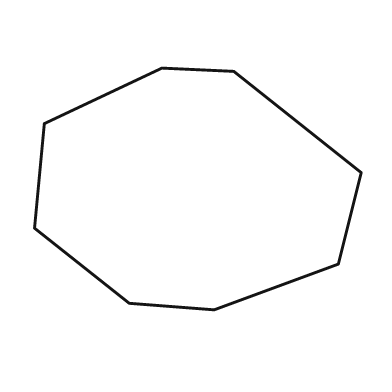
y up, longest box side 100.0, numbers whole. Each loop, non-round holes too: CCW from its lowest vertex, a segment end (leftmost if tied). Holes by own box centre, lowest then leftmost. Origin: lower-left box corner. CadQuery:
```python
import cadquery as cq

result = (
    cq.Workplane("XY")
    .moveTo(55.0, 0.0)
    .lineTo(93.0, 14.0)
    .lineTo(100.0, 42.0)
    .lineTo(61.0, 73.0)
    .lineTo(39.0, 74.0)
    .lineTo(3.0, 57.0)
    .lineTo(0.0, 25.0)
    .lineTo(29.0, 2.0)
    .close()
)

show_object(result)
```